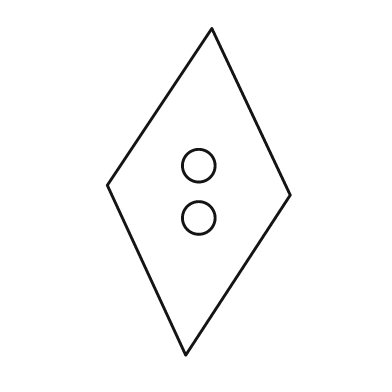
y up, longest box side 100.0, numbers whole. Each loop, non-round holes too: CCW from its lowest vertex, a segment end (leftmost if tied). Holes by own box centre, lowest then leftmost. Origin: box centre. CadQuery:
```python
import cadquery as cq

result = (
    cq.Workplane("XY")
    .moveTo(-4.0, -50.0)
    .lineTo(28.0, -1.0)
    .lineTo(4.0, 50.0)
    .lineTo(-28.0, 2.0)
    .close()
    .moveTo(0.0, -8.0)
    .circle(5.0)
    .moveTo(0.0, 8.0)
    .circle(5.0)
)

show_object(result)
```